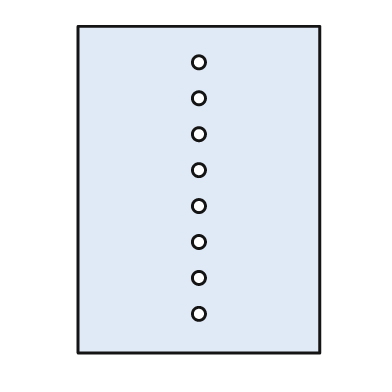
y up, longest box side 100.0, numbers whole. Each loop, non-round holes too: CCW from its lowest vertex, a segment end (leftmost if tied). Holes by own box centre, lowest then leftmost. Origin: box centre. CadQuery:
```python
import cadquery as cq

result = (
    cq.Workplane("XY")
    .moveTo(-37.0, -50.0)
    .lineTo(37.0, -50.0)
    .lineTo(37.0, 50.0)
    .lineTo(-37.0, 50.0)
    .close()
    .moveTo(0.0, -38.0)
    .circle(2.0)
    .moveTo(0.0, -27.0)
    .circle(2.0)
    .moveTo(0.0, -16.0)
    .circle(2.0)
    .moveTo(0.0, -5.0)
    .circle(2.0)
    .moveTo(0.0, 6.0)
    .circle(2.0)
    .moveTo(0.0, 17.0)
    .circle(2.0)
    .moveTo(0.0, 28.0)
    .circle(2.0)
    .moveTo(0.0, 39.0)
    .circle(2.0)
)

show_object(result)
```